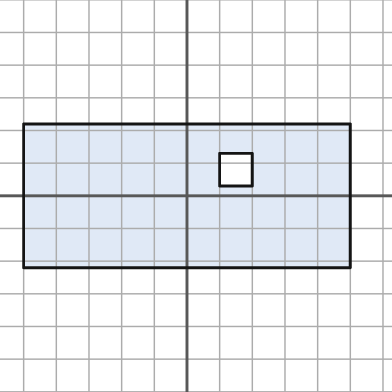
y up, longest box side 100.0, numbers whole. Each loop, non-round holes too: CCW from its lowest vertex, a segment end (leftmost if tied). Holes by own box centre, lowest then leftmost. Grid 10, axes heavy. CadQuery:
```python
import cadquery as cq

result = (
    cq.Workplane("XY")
    .moveTo(-50.0, -22.0)
    .lineTo(50.0, -22.0)
    .lineTo(50.0, 22.0)
    .lineTo(-50.0, 22.0)
    .close()
    .moveTo(10.0, 3.0)
    .lineTo(20.0, 3.0)
    .lineTo(20.0, 13.0)
    .lineTo(10.0, 13.0)
    .close()
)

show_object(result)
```